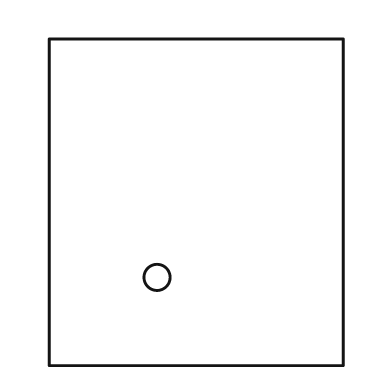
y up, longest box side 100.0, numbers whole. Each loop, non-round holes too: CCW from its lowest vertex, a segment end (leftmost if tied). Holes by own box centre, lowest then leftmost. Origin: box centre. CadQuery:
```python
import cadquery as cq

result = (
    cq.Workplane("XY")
    .moveTo(-45.0, -50.0)
    .lineTo(45.0, -50.0)
    .lineTo(45.0, 50.0)
    .lineTo(-45.0, 50.0)
    .close()
    .moveTo(-12.0, -23.0)
    .circle(4.0)
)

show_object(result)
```